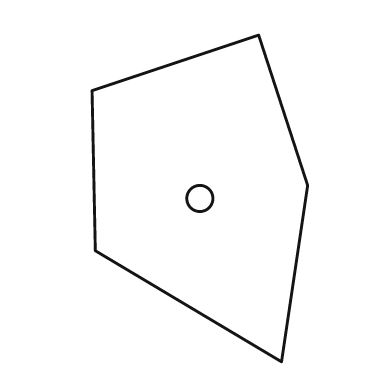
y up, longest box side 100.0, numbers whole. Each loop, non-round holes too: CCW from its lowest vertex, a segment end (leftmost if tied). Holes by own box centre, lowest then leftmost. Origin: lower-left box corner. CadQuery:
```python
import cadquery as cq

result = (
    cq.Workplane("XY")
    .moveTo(58.0, 0.0)
    .lineTo(66.0, 54.0)
    .lineTo(51.0, 100.0)
    .lineTo(0.0, 83.0)
    .lineTo(1.0, 34.0)
    .close()
    .moveTo(33.0, 50.0)
    .circle(4.0)
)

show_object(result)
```